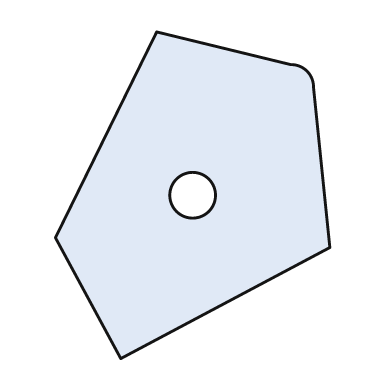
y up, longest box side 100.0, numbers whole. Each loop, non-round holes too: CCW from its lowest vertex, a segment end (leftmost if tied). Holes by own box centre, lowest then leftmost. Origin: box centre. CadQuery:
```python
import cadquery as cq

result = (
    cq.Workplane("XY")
    .moveTo(-22.0, -50.0)
    .lineTo(42.0, -16.0)
    .lineTo(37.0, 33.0)
    .threePointArc((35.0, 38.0), (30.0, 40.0))
    .lineTo(-11.0, 50.0)
    .lineTo(-42.0, -13.0)
    .close()
    .moveTo(0.0, 0.0)
    .circle(7.0)
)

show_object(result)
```